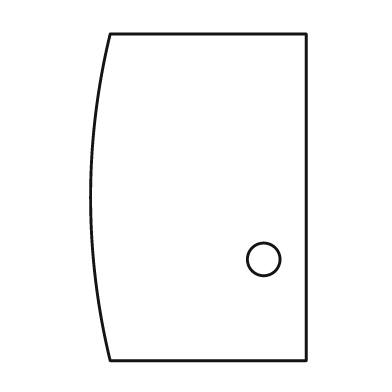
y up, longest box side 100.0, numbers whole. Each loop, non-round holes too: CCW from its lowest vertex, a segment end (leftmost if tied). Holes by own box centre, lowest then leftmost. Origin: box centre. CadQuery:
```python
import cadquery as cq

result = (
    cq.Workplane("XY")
    .moveTo(-27.0, -50.0)
    .lineTo(33.0, -50.0)
    .lineTo(33.0, 50.0)
    .lineTo(-27.0, 50.0)
    .threePointArc((-33.0, 0.0), (-27.0, -50.0))
    .close()
    .moveTo(20.0, -19.0)
    .circle(5.0)
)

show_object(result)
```